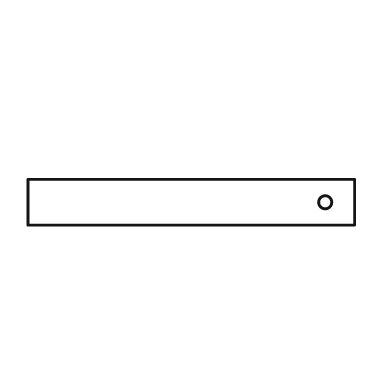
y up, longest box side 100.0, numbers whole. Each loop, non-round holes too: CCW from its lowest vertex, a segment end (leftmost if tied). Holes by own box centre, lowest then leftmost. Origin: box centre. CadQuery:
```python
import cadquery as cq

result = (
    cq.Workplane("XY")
    .moveTo(-50.0, -7.0)
    .lineTo(50.0, -7.0)
    .lineTo(50.0, 7.0)
    .lineTo(-50.0, 7.0)
    .close()
    .moveTo(41.0, 0.0)
    .circle(2.0)
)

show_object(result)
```